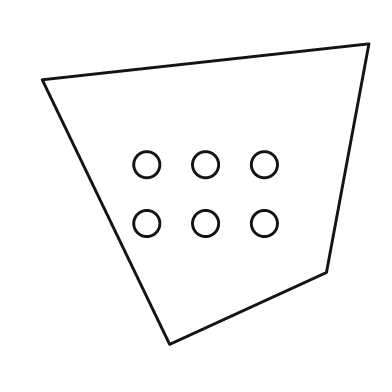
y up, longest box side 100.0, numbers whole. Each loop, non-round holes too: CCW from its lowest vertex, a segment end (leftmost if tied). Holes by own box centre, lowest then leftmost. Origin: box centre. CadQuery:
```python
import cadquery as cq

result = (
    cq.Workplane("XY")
    .moveTo(-11.0, -46.0)
    .lineTo(37.0, -24.0)
    .lineTo(50.0, 46.0)
    .lineTo(-50.0, 35.0)
    .close()
    .moveTo(-18.0, -9.0)
    .circle(4.0)
    .moveTo(0.0, -9.0)
    .circle(4.0)
    .moveTo(18.0, -9.0)
    .circle(4.0)
    .moveTo(-18.0, 9.0)
    .circle(4.0)
    .moveTo(0.0, 9.0)
    .circle(4.0)
    .moveTo(18.0, 9.0)
    .circle(4.0)
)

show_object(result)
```